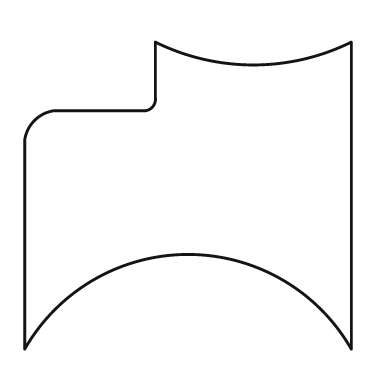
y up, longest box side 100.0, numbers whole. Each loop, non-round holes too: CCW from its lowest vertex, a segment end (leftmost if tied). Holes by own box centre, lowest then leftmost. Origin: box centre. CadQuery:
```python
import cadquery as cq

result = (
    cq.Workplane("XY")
    .moveTo(-50.0, -47.0)
    .threePointArc((0.0, -18.0), (50.0, -47.0))
    .lineTo(50.0, 47.0)
    .threePointArc((20.0, 40.0), (-10.0, 47.0))
    .lineTo(-10.0, 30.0)
    .threePointArc((-11.0, 27.0), (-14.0, 26.0))
    .lineTo(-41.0, 26.0)
    .threePointArc((-47.0, 23.0), (-50.0, 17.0))
    .close()
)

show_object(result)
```